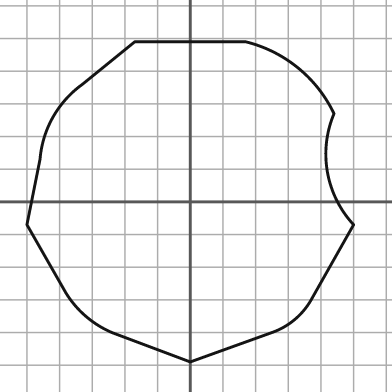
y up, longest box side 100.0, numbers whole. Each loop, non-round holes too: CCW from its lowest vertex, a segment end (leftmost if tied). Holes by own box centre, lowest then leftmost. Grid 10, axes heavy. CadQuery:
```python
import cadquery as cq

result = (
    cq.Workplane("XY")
    .moveTo(0.0, -49.0)
    .lineTo(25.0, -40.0)
    .threePointArc((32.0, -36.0), (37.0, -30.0))
    .lineTo(50.0, -7.0)
    .threePointArc((42.0, 9.0), (44.0, 27.0))
    .threePointArc((33.0, 41.0), (17.0, 49.0))
    .lineTo(-17.0, 49.0)
    .lineTo(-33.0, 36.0)
    .threePointArc((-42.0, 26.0), (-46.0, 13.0))
    .lineTo(-50.0, -7.0)
    .lineTo(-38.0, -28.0)
    .threePointArc((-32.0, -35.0), (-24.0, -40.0))
    .close()
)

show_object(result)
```